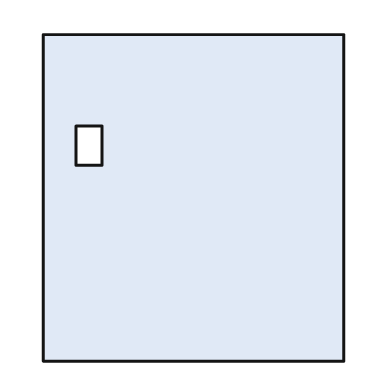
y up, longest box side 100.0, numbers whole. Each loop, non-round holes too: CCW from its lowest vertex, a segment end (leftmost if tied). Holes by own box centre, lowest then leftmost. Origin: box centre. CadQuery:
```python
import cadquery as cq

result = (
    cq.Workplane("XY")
    .moveTo(-46.0, -50.0)
    .lineTo(46.0, -50.0)
    .lineTo(46.0, 50.0)
    .lineTo(-46.0, 50.0)
    .close()
    .moveTo(-36.0, 10.0)
    .lineTo(-28.0, 10.0)
    .lineTo(-28.0, 22.0)
    .lineTo(-36.0, 22.0)
    .close()
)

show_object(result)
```